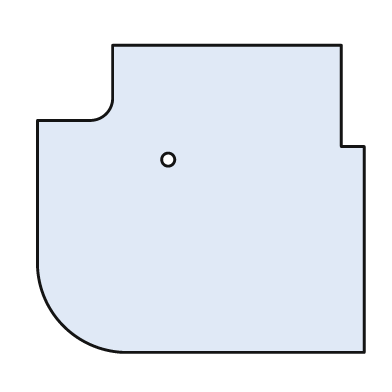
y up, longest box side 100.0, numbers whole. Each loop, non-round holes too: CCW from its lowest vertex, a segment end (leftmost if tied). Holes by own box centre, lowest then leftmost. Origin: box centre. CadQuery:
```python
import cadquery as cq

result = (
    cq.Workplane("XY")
    .moveTo(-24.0, -47.0)
    .lineTo(50.0, -47.0)
    .lineTo(50.0, 16.0)
    .lineTo(43.0, 16.0)
    .lineTo(43.0, 47.0)
    .lineTo(-27.0, 47.0)
    .lineTo(-27.0, 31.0)
    .threePointArc((-29.0, 26.0), (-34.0, 24.0))
    .lineTo(-50.0, 24.0)
    .lineTo(-50.0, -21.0)
    .threePointArc((-42.0, -39.0), (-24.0, -47.0))
    .close()
    .moveTo(-10.0, 12.0)
    .circle(2.0)
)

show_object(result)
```